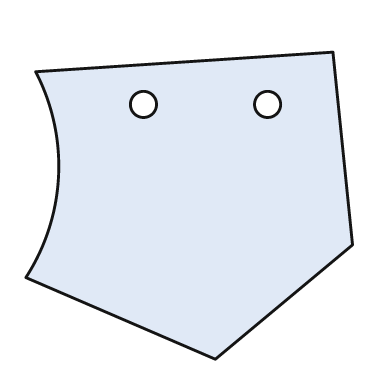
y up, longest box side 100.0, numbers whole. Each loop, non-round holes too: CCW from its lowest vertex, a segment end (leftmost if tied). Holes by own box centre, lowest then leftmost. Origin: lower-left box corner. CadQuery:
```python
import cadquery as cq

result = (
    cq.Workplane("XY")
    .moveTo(58.0, 0.0)
    .lineTo(100.0, 35.0)
    .lineTo(94.0, 94.0)
    .lineTo(3.0, 88.0)
    .threePointArc((10.0, 56.0), (0.0, 25.0))
    .close()
    .moveTo(36.0, 78.0)
    .circle(4.0)
    .moveTo(74.0, 78.0)
    .circle(4.0)
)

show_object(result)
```